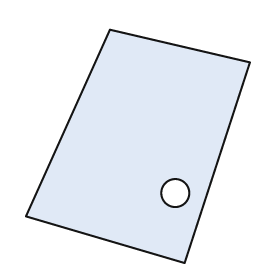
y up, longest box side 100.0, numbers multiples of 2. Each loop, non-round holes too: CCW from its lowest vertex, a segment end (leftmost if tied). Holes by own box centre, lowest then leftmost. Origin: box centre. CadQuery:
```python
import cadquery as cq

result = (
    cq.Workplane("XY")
    .moveTo(20.0, -50.0)
    .lineTo(48.0, 36.0)
    .lineTo(-12.0, 50.0)
    .lineTo(-48.0, -30.0)
    .close()
    .moveTo(16.0, -20.0)
    .circle(6.0)
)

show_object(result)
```